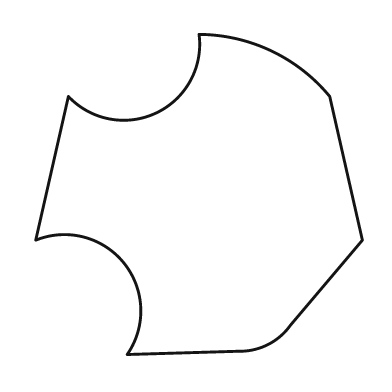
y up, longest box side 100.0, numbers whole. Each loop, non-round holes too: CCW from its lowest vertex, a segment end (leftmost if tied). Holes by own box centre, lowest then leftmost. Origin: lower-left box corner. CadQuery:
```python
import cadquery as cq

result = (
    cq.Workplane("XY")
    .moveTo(28.0, 0.0)
    .lineTo(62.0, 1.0)
    .threePointArc((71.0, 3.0), (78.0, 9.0))
    .lineTo(100.0, 35.0)
    .lineTo(90.0, 79.0)
    .threePointArc((72.0, 93.0), (50.0, 98.0))
    .threePointArc((37.0, 74.0), (10.0, 79.0))
    .lineTo(0.0, 35.0)
    .threePointArc((27.0, 28.0), (28.0, 0.0))
    .close()
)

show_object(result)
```